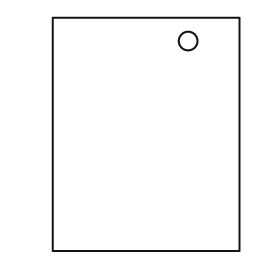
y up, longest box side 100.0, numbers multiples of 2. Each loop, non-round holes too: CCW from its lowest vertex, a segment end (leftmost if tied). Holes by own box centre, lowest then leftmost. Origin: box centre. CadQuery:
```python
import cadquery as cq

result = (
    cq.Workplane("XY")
    .moveTo(-40.0, -50.0)
    .lineTo(40.0, -50.0)
    .lineTo(40.0, 50.0)
    .lineTo(-40.0, 50.0)
    .close()
    .moveTo(18.0, 40.0)
    .circle(4.0)
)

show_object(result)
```